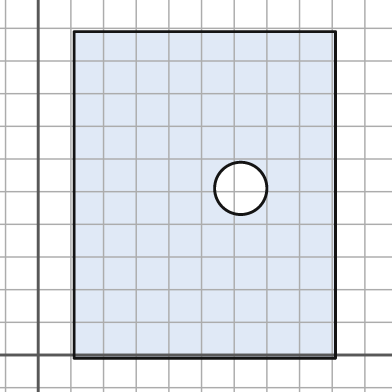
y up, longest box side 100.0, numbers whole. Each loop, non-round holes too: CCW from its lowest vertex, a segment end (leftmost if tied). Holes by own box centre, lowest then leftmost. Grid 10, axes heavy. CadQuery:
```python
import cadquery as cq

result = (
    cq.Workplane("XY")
    .moveTo(11.0, -1.0)
    .lineTo(91.0, -1.0)
    .lineTo(91.0, 99.0)
    .lineTo(11.0, 99.0)
    .close()
    .moveTo(62.0, 51.0)
    .circle(8.0)
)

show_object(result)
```